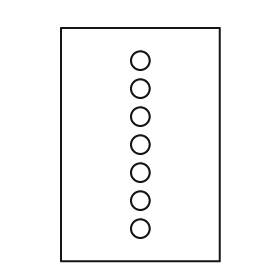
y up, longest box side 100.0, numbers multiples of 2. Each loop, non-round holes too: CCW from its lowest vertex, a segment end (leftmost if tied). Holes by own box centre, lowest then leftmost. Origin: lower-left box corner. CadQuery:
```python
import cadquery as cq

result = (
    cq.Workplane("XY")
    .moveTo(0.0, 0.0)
    .lineTo(68.0, 0.0)
    .lineTo(68.0, 100.0)
    .lineTo(0.0, 100.0)
    .close()
    .moveTo(34.0, 14.0)
    .circle(4.0)
    .moveTo(34.0, 26.0)
    .circle(4.0)
    .moveTo(34.0, 38.0)
    .circle(4.0)
    .moveTo(34.0, 50.0)
    .circle(4.0)
    .moveTo(34.0, 62.0)
    .circle(4.0)
    .moveTo(34.0, 74.0)
    .circle(4.0)
    .moveTo(34.0, 86.0)
    .circle(4.0)
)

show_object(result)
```